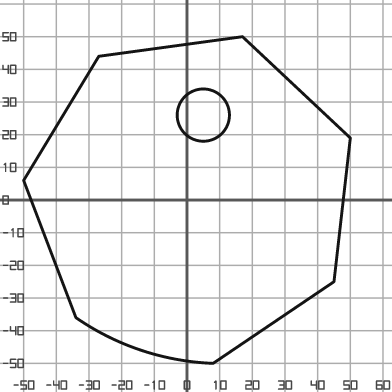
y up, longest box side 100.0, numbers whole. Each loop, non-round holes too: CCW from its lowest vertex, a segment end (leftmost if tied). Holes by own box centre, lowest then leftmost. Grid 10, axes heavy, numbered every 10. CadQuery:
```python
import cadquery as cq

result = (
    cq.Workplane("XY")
    .moveTo(8.0, -50.0)
    .lineTo(45.0, -25.0)
    .lineTo(50.0, 19.0)
    .lineTo(17.0, 50.0)
    .lineTo(-27.0, 44.0)
    .lineTo(-50.0, 6.0)
    .lineTo(-34.0, -36.0)
    .threePointArc((-14.0, -46.0), (8.0, -50.0))
    .close()
    .moveTo(5.0, 26.0)
    .circle(8.0)
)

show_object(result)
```